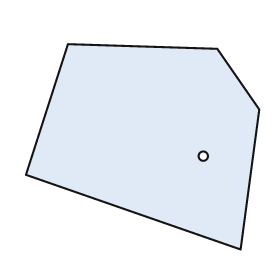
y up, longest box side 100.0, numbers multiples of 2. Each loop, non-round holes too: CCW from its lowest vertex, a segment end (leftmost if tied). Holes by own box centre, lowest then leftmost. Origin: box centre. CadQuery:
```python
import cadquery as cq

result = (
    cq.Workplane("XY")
    .moveTo(42.0, -44.0)
    .lineTo(50.0, 16.0)
    .lineTo(32.0, 42.0)
    .lineTo(-32.0, 44.0)
    .lineTo(-50.0, -12.0)
    .close()
    .moveTo(26.0, -4.0)
    .circle(2.0)
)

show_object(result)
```